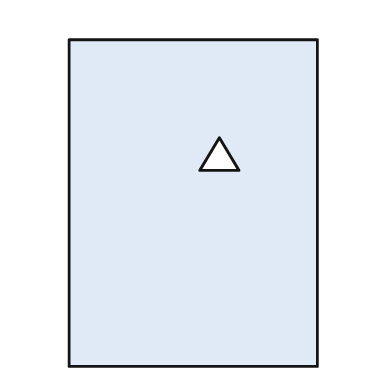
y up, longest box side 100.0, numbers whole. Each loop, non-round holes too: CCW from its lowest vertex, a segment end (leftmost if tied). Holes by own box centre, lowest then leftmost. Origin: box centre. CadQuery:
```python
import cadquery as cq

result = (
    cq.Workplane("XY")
    .moveTo(-38.0, -50.0)
    .lineTo(38.0, -50.0)
    .lineTo(38.0, 50.0)
    .lineTo(-38.0, 50.0)
    .close()
    .moveTo(2.0, 10.0)
    .lineTo(14.0, 10.0)
    .lineTo(8.0, 20.0)
    .close()
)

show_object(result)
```